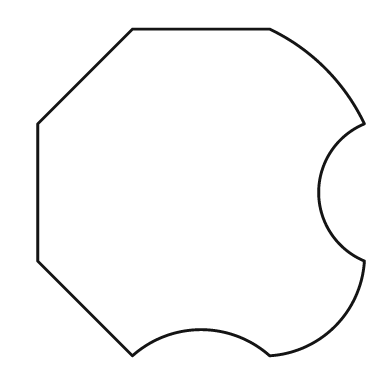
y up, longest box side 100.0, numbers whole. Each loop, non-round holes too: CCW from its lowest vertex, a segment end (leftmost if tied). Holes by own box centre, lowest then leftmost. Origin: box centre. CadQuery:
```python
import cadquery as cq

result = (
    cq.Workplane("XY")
    .moveTo(-21.0, -50.0)
    .threePointArc((0.0, -42.0), (21.0, -50.0))
    .threePointArc((41.0, -41.0), (50.0, -21.0))
    .threePointArc((36.0, 0.0), (50.0, 21.0))
    .threePointArc((38.0, 38.0), (21.0, 50.0))
    .lineTo(-21.0, 50.0)
    .lineTo(-50.0, 21.0)
    .lineTo(-50.0, -21.0)
    .close()
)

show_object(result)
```